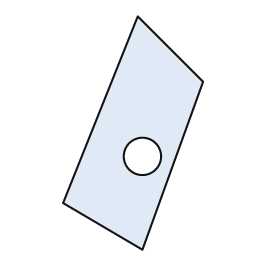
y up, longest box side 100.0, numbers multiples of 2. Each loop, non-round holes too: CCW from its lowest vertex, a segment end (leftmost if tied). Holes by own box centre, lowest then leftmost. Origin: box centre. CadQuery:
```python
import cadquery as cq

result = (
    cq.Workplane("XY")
    .moveTo(4.0, -50.0)
    .lineTo(30.0, 22.0)
    .lineTo(2.0, 50.0)
    .lineTo(-30.0, -30.0)
    .close()
    .moveTo(4.0, -10.0)
    .circle(8.0)
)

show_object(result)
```